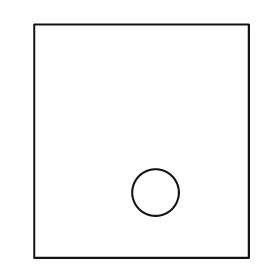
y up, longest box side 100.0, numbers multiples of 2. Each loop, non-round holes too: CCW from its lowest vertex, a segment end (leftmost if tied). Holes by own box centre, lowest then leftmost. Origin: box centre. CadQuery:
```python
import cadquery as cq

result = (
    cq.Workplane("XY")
    .moveTo(-46.0, -50.0)
    .lineTo(46.0, -50.0)
    .lineTo(46.0, 50.0)
    .lineTo(-46.0, 50.0)
    .close()
    .moveTo(6.0, -22.0)
    .circle(10.0)
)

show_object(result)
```